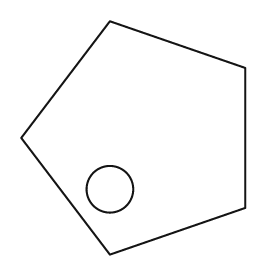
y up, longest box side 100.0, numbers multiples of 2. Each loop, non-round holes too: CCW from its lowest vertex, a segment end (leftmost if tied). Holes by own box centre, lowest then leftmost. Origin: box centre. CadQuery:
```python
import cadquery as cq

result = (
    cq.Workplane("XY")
    .moveTo(-10.0, -50.0)
    .lineTo(48.0, -30.0)
    .lineTo(48.0, 30.0)
    .lineTo(-10.0, 50.0)
    .lineTo(-48.0, 0.0)
    .close()
    .moveTo(-10.0, -22.0)
    .circle(10.0)
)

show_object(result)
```